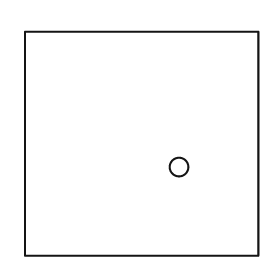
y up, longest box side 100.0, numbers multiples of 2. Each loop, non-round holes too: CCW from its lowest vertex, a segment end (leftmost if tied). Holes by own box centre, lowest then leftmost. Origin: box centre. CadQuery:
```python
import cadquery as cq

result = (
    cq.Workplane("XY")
    .moveTo(-50.0, -48.0)
    .lineTo(50.0, -48.0)
    .lineTo(50.0, 48.0)
    .lineTo(-50.0, 48.0)
    .close()
    .moveTo(16.0, -10.0)
    .circle(4.0)
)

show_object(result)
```